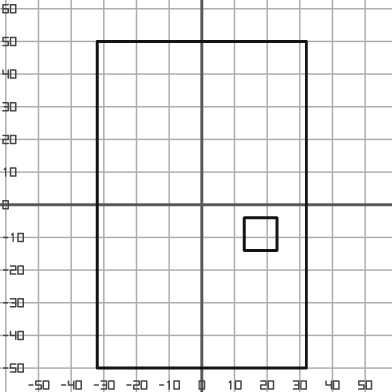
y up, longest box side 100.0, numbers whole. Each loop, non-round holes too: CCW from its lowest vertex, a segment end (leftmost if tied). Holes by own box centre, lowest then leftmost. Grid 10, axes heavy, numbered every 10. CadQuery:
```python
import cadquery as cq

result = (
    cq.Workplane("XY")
    .moveTo(-32.0, -50.0)
    .lineTo(32.0, -50.0)
    .lineTo(32.0, 50.0)
    .lineTo(-32.0, 50.0)
    .close()
    .moveTo(13.0, -14.0)
    .lineTo(23.0, -14.0)
    .lineTo(23.0, -4.0)
    .lineTo(13.0, -4.0)
    .close()
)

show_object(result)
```